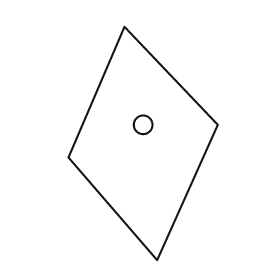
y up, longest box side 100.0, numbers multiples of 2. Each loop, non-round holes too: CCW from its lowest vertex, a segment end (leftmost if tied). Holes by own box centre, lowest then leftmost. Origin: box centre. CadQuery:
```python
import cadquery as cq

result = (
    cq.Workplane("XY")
    .moveTo(6.0, -50.0)
    .lineTo(32.0, 8.0)
    .lineTo(-8.0, 50.0)
    .lineTo(-32.0, -6.0)
    .close()
    .moveTo(0.0, 8.0)
    .circle(4.0)
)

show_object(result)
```